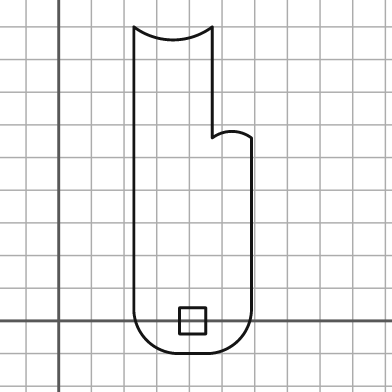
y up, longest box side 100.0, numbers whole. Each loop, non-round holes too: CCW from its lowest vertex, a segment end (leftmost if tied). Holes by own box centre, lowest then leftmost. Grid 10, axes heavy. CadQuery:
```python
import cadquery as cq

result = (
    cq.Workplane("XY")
    .moveTo(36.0, -10.0)
    .lineTo(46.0, -10.0)
    .threePointArc((55.0, -6.0), (59.0, 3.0))
    .lineTo(59.0, 56.0)
    .threePointArc((53.0, 58.0), (47.0, 56.0))
    .lineTo(47.0, 90.0)
    .threePointArc((35.0, 86.0), (23.0, 90.0))
    .lineTo(23.0, 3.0)
    .threePointArc((27.0, -6.0), (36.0, -10.0))
    .close()
    .moveTo(37.0, -4.0)
    .lineTo(45.0, -4.0)
    .lineTo(45.0, 4.0)
    .lineTo(37.0, 4.0)
    .close()
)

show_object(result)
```